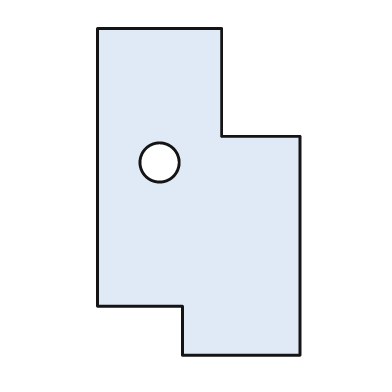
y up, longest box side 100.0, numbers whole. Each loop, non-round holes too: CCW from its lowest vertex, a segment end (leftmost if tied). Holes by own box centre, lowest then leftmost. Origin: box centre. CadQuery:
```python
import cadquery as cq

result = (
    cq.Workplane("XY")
    .moveTo(-5.0, -50.0)
    .lineTo(31.0, -50.0)
    .lineTo(31.0, 17.0)
    .lineTo(7.0, 17.0)
    .lineTo(7.0, 50.0)
    .lineTo(-31.0, 50.0)
    .lineTo(-31.0, -35.0)
    .lineTo(-5.0, -35.0)
    .close()
    .moveTo(-12.0, 9.0)
    .circle(6.0)
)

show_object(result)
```